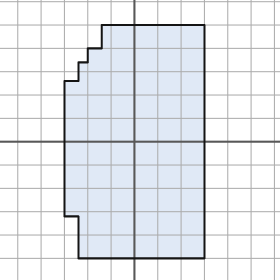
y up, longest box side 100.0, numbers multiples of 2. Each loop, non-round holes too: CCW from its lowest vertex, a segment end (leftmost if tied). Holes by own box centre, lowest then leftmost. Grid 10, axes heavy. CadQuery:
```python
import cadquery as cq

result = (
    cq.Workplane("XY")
    .moveTo(-24.0, -50.0)
    .lineTo(30.0, -50.0)
    .lineTo(30.0, 50.0)
    .lineTo(-14.0, 50.0)
    .lineTo(-14.0, 40.0)
    .lineTo(-20.0, 40.0)
    .lineTo(-20.0, 34.0)
    .lineTo(-24.0, 34.0)
    .lineTo(-24.0, 26.0)
    .lineTo(-30.0, 26.0)
    .lineTo(-30.0, -32.0)
    .lineTo(-24.0, -32.0)
    .close()
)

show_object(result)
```